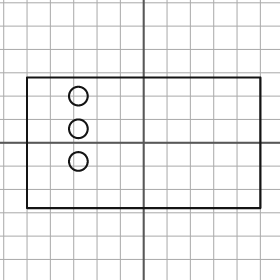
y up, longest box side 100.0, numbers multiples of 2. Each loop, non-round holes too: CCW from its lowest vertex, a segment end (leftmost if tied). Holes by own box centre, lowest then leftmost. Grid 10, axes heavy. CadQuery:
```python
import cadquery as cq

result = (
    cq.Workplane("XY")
    .moveTo(-50.0, -28.0)
    .lineTo(50.0, -28.0)
    .lineTo(50.0, 28.0)
    .lineTo(-50.0, 28.0)
    .close()
    .moveTo(-28.0, -8.0)
    .circle(4.0)
    .moveTo(-28.0, 6.0)
    .circle(4.0)
    .moveTo(-28.0, 20.0)
    .circle(4.0)
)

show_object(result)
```